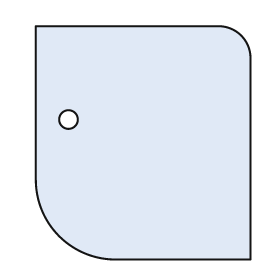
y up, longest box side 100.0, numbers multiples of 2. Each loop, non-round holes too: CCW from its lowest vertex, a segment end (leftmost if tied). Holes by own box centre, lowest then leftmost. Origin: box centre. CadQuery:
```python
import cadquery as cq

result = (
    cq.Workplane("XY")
    .moveTo(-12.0, -50.0)
    .lineTo(46.0, -50.0)
    .lineTo(46.0, 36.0)
    .threePointArc((42.0, 46.0), (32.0, 50.0))
    .lineTo(-46.0, 50.0)
    .lineTo(-46.0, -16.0)
    .threePointArc((-36.0, -40.0), (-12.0, -50.0))
    .close()
    .moveTo(-32.0, 10.0)
    .circle(4.0)
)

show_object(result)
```